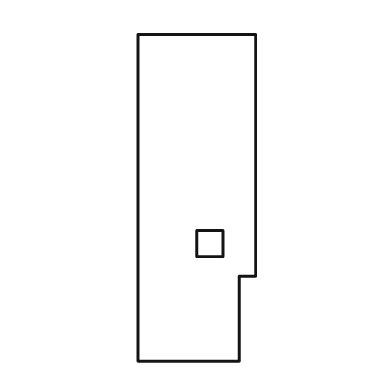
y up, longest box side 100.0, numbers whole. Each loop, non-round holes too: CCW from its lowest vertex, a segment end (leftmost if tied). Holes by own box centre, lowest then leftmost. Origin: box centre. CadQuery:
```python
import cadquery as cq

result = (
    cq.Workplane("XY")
    .moveTo(-18.0, -50.0)
    .lineTo(13.0, -50.0)
    .lineTo(13.0, -24.0)
    .lineTo(18.0, -24.0)
    .lineTo(18.0, 50.0)
    .lineTo(-18.0, 50.0)
    .close()
    .moveTo(0.0, -18.0)
    .lineTo(8.0, -18.0)
    .lineTo(8.0, -10.0)
    .lineTo(0.0, -10.0)
    .close()
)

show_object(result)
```